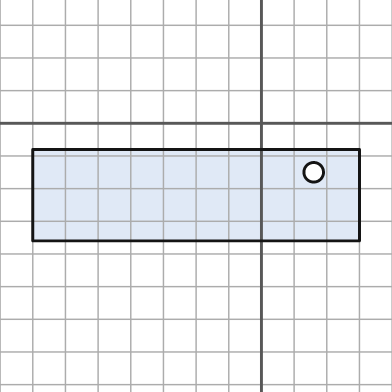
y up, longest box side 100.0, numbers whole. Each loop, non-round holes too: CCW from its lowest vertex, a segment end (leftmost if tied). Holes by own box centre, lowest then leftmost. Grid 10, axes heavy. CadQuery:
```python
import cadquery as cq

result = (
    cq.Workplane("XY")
    .moveTo(-70.0, -36.0)
    .lineTo(30.0, -36.0)
    .lineTo(30.0, -8.0)
    .lineTo(-70.0, -8.0)
    .close()
    .moveTo(16.0, -15.0)
    .circle(3.0)
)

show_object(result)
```